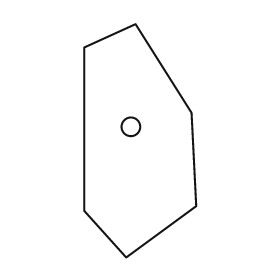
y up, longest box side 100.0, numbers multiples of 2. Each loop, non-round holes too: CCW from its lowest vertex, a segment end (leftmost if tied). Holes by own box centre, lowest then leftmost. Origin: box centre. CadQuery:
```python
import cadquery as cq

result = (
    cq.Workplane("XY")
    .moveTo(-6.0, -50.0)
    .lineTo(24.0, -28.0)
    .lineTo(22.0, 12.0)
    .lineTo(-2.0, 50.0)
    .lineTo(-24.0, 40.0)
    .lineTo(-24.0, -30.0)
    .close()
    .moveTo(-4.0, 6.0)
    .circle(4.0)
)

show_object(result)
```